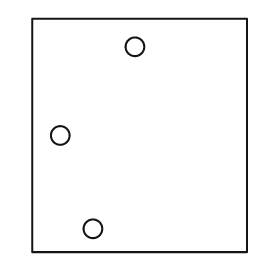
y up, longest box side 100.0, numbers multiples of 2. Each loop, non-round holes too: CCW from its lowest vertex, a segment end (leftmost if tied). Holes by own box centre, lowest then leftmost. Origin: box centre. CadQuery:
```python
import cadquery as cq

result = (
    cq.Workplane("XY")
    .moveTo(-46.0, -50.0)
    .lineTo(46.0, -50.0)
    .lineTo(46.0, 50.0)
    .lineTo(-46.0, 50.0)
    .close()
    .moveTo(-20.0, -40.0)
    .circle(4.0)
    .moveTo(-34.0, 0.0)
    .circle(4.0)
    .moveTo(-2.0, 38.0)
    .circle(4.0)
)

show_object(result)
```